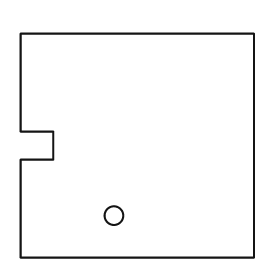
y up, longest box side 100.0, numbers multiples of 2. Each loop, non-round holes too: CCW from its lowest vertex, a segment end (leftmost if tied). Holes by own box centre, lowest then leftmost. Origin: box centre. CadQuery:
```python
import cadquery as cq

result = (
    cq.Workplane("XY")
    .moveTo(-50.0, -48.0)
    .lineTo(50.0, -48.0)
    .lineTo(50.0, 48.0)
    .lineTo(-50.0, 48.0)
    .lineTo(-50.0, 6.0)
    .lineTo(-36.0, 6.0)
    .lineTo(-36.0, -6.0)
    .lineTo(-50.0, -6.0)
    .close()
    .moveTo(-10.0, -30.0)
    .circle(4.0)
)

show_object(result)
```